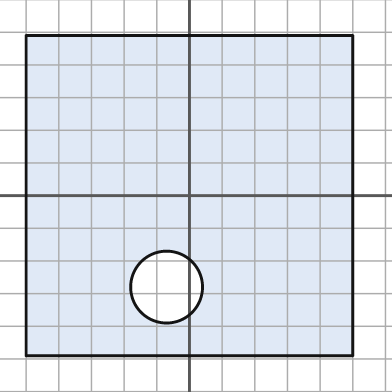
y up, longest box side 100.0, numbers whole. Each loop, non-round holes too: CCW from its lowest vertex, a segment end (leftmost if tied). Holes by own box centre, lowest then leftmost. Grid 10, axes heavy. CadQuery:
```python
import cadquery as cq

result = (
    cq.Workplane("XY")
    .moveTo(-50.0, -49.0)
    .lineTo(50.0, -49.0)
    .lineTo(50.0, 49.0)
    .lineTo(-50.0, 49.0)
    .close()
    .moveTo(-7.0, -28.0)
    .circle(11.0)
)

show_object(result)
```